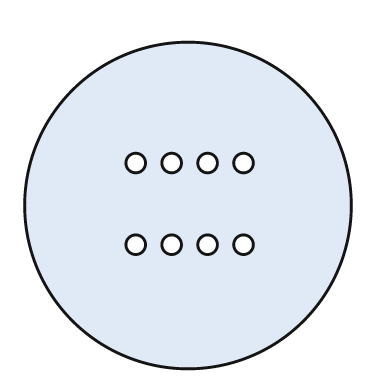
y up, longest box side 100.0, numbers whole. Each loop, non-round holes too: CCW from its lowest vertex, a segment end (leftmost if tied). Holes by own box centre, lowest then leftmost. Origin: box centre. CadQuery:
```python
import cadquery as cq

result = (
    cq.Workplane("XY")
    .moveTo(0.0, 0.0)
    .circle(50.0)
    .moveTo(-16.0, -12.0)
    .circle(3.0)
    .moveTo(-5.0, -12.0)
    .circle(3.0)
    .moveTo(6.0, -12.0)
    .circle(3.0)
    .moveTo(17.0, -12.0)
    .circle(3.0)
    .moveTo(-16.0, 13.0)
    .circle(3.0)
    .moveTo(-5.0, 13.0)
    .circle(3.0)
    .moveTo(6.0, 13.0)
    .circle(3.0)
    .moveTo(17.0, 13.0)
    .circle(3.0)
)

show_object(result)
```